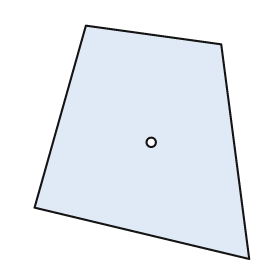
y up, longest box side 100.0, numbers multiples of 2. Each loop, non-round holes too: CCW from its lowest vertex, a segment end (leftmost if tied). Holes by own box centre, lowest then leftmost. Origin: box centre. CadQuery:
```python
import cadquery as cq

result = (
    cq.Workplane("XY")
    .moveTo(46.0, -50.0)
    .lineTo(34.0, 42.0)
    .lineTo(-24.0, 50.0)
    .lineTo(-46.0, -28.0)
    .close()
    .moveTo(4.0, 0.0)
    .circle(2.0)
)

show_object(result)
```